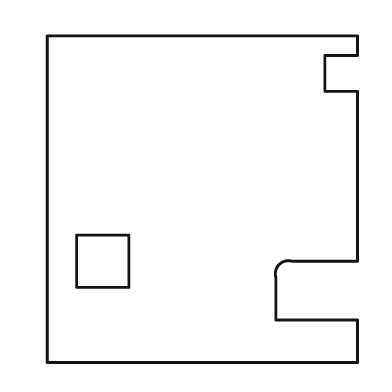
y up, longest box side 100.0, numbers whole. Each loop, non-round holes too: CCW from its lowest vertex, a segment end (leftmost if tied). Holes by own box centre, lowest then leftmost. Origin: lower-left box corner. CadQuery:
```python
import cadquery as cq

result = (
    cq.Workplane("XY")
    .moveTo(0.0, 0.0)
    .lineTo(95.0, 0.0)
    .lineTo(95.0, 13.0)
    .lineTo(70.0, 13.0)
    .lineTo(70.0, 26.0)
    .threePointArc((71.0, 30.0), (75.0, 31.0))
    .lineTo(95.0, 31.0)
    .lineTo(95.0, 83.0)
    .lineTo(85.0, 83.0)
    .lineTo(85.0, 94.0)
    .lineTo(95.0, 94.0)
    .lineTo(95.0, 100.0)
    .lineTo(0.0, 100.0)
    .close()
    .moveTo(9.0, 23.0)
    .lineTo(25.0, 23.0)
    .lineTo(25.0, 39.0)
    .lineTo(9.0, 39.0)
    .close()
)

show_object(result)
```